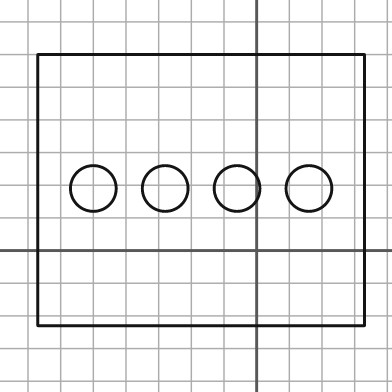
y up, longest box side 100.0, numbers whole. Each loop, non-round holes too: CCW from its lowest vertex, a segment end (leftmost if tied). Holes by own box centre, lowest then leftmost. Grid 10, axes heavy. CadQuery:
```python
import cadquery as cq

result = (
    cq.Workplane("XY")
    .moveTo(-67.0, -23.0)
    .lineTo(33.0, -23.0)
    .lineTo(33.0, 60.0)
    .lineTo(-67.0, 60.0)
    .close()
    .moveTo(-50.0, 19.0)
    .circle(7.0)
    .moveTo(-28.0, 19.0)
    .circle(7.0)
    .moveTo(-6.0, 19.0)
    .circle(7.0)
    .moveTo(16.0, 19.0)
    .circle(7.0)
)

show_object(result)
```